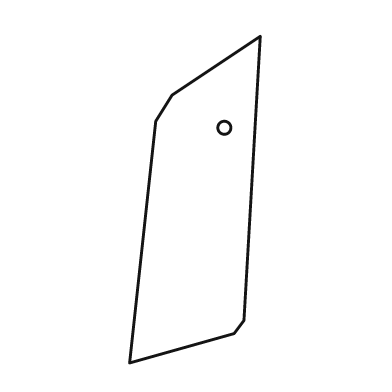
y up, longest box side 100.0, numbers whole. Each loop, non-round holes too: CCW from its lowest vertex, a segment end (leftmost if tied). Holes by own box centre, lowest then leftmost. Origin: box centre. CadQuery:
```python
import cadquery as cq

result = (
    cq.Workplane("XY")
    .moveTo(-20.0, -50.0)
    .lineTo(12.0, -41.0)
    .lineTo(15.0, -37.0)
    .lineTo(20.0, 50.0)
    .lineTo(-7.0, 32.0)
    .lineTo(-12.0, 24.0)
    .close()
    .moveTo(9.0, 22.0)
    .circle(2.0)
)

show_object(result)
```